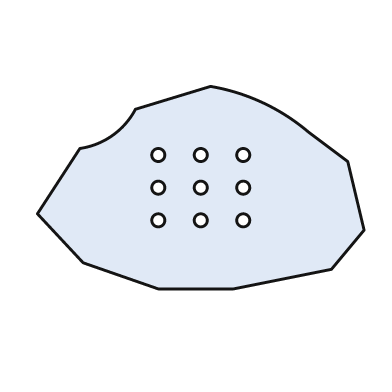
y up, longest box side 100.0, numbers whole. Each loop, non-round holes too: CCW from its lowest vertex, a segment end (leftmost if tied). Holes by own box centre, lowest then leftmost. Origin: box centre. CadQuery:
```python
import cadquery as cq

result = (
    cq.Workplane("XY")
    .moveTo(-13.0, -31.0)
    .lineTo(10.0, -31.0)
    .lineTo(40.0, -25.0)
    .lineTo(50.0, -13.0)
    .lineTo(45.0, 8.0)
    .lineTo(33.0, 17.0)
    .threePointArc((19.0, 26.0), (3.0, 31.0))
    .lineTo(-20.0, 24.0)
    .threePointArc((-27.0, 16.0), (-37.0, 12.0))
    .lineTo(-50.0, -8.0)
    .lineTo(-36.0, -23.0)
    .close()
    .moveTo(-13.0, -10.0)
    .circle(2.0)
    .moveTo(0.0, -10.0)
    .circle(2.0)
    .moveTo(13.0, -10.0)
    .circle(2.0)
    .moveTo(-13.0, 0.0)
    .circle(2.0)
    .moveTo(0.0, 0.0)
    .circle(2.0)
    .moveTo(13.0, 0.0)
    .circle(2.0)
    .moveTo(-13.0, 10.0)
    .circle(2.0)
    .moveTo(0.0, 10.0)
    .circle(2.0)
    .moveTo(13.0, 10.0)
    .circle(2.0)
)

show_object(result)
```